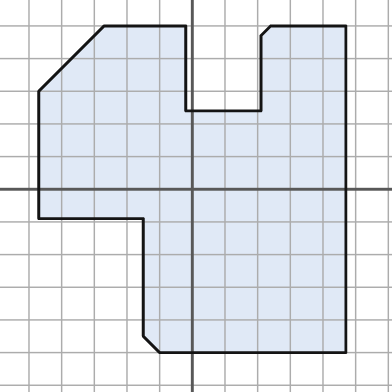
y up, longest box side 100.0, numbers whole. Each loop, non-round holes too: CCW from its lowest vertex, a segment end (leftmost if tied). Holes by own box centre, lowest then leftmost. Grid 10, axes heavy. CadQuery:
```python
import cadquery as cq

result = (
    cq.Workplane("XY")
    .moveTo(-10.0, -50.0)
    .lineTo(47.0, -50.0)
    .lineTo(47.0, 50.0)
    .lineTo(24.0, 50.0)
    .lineTo(21.0, 47.0)
    .lineTo(21.0, 24.0)
    .lineTo(-2.0, 24.0)
    .lineTo(-2.0, 50.0)
    .lineTo(-27.0, 50.0)
    .lineTo(-47.0, 30.0)
    .lineTo(-47.0, -9.0)
    .lineTo(-15.0, -9.0)
    .lineTo(-15.0, -45.0)
    .close()
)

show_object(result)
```